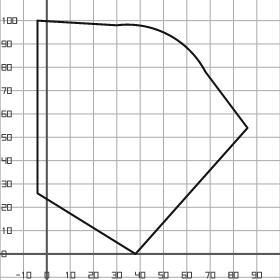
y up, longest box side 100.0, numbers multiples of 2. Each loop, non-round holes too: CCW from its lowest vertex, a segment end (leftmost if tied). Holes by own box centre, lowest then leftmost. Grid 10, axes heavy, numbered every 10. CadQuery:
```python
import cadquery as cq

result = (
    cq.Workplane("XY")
    .moveTo(38.0, 0.0)
    .lineTo(86.0, 54.0)
    .lineTo(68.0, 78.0)
    .threePointArc((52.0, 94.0), (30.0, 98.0))
    .lineTo(-4.0, 100.0)
    .lineTo(-4.0, 26.0)
    .close()
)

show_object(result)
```